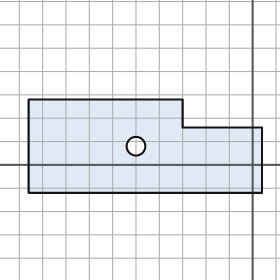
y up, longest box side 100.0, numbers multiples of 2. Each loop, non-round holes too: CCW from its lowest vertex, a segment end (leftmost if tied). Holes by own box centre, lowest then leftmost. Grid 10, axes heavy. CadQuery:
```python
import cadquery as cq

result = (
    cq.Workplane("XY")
    .moveTo(-96.0, -12.0)
    .lineTo(4.0, -12.0)
    .lineTo(4.0, 16.0)
    .lineTo(-30.0, 16.0)
    .lineTo(-30.0, 28.0)
    .lineTo(-96.0, 28.0)
    .close()
    .moveTo(-50.0, 8.0)
    .circle(4.0)
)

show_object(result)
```